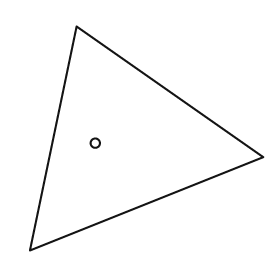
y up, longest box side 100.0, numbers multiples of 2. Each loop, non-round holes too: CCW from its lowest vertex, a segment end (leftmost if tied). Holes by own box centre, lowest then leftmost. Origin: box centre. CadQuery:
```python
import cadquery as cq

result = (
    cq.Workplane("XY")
    .moveTo(-50.0, -48.0)
    .lineTo(50.0, -8.0)
    .lineTo(-30.0, 48.0)
    .close()
    .moveTo(-22.0, -2.0)
    .circle(2.0)
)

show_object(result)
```